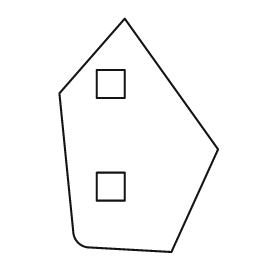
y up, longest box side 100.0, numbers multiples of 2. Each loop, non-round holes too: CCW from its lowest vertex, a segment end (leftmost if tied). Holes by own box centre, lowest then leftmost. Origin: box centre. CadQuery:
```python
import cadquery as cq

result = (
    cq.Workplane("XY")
    .moveTo(14.0, -50.0)
    .lineTo(34.0, -6.0)
    .lineTo(-6.0, 50.0)
    .lineTo(-34.0, 18.0)
    .lineTo(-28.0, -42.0)
    .threePointArc((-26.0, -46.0), (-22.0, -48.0))
    .close()
    .moveTo(-18.0, -28.0)
    .lineTo(-6.0, -28.0)
    .lineTo(-6.0, -16.0)
    .lineTo(-18.0, -16.0)
    .close()
    .moveTo(-18.0, 16.0)
    .lineTo(-6.0, 16.0)
    .lineTo(-6.0, 28.0)
    .lineTo(-18.0, 28.0)
    .close()
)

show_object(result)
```